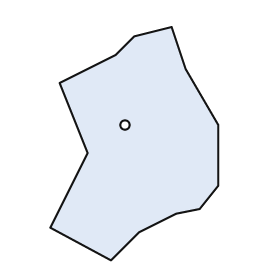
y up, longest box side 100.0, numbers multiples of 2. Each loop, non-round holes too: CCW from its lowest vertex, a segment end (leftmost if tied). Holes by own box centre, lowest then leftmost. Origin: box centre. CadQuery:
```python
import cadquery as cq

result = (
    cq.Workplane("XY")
    .moveTo(-10.0, -50.0)
    .lineTo(2.0, -38.0)
    .lineTo(18.0, -30.0)
    .lineTo(28.0, -28.0)
    .lineTo(36.0, -18.0)
    .lineTo(36.0, 8.0)
    .lineTo(22.0, 32.0)
    .lineTo(16.0, 50.0)
    .lineTo(0.0, 46.0)
    .lineTo(-8.0, 38.0)
    .lineTo(-32.0, 26.0)
    .lineTo(-20.0, -4.0)
    .lineTo(-36.0, -36.0)
    .close()
    .moveTo(-4.0, 8.0)
    .circle(2.0)
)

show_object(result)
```